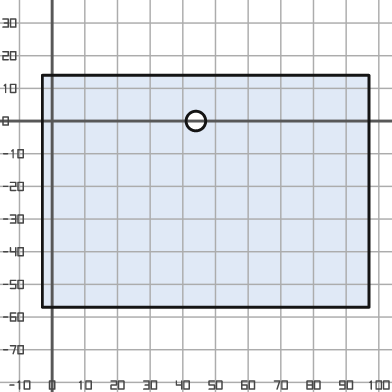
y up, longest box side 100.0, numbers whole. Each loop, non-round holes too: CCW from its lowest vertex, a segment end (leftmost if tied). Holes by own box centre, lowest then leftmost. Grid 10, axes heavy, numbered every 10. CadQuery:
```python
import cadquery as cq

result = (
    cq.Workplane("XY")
    .moveTo(-3.0, -57.0)
    .lineTo(97.0, -57.0)
    .lineTo(97.0, 14.0)
    .lineTo(-3.0, 14.0)
    .close()
    .moveTo(44.0, 0.0)
    .circle(3.0)
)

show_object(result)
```